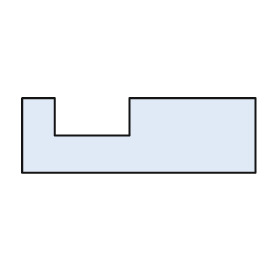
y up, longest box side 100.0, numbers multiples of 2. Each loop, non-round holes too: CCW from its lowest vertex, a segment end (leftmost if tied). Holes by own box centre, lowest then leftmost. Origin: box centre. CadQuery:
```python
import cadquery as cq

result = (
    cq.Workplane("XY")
    .moveTo(-50.0, -16.0)
    .lineTo(50.0, -16.0)
    .lineTo(50.0, 16.0)
    .lineTo(-4.0, 16.0)
    .lineTo(-4.0, 0.0)
    .lineTo(-36.0, 0.0)
    .lineTo(-36.0, 16.0)
    .lineTo(-50.0, 16.0)
    .close()
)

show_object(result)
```